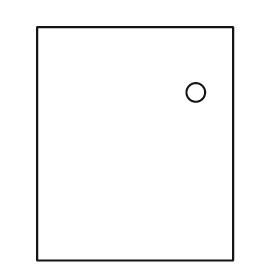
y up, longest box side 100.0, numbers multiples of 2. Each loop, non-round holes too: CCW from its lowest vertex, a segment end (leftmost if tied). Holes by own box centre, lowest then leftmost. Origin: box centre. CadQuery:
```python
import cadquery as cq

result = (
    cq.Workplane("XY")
    .moveTo(-42.0, -50.0)
    .lineTo(42.0, -50.0)
    .lineTo(42.0, 50.0)
    .lineTo(-42.0, 50.0)
    .close()
    .moveTo(26.0, 22.0)
    .circle(4.0)
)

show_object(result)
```